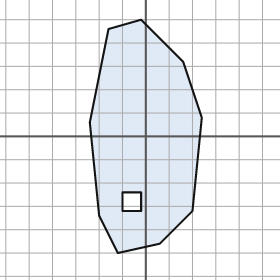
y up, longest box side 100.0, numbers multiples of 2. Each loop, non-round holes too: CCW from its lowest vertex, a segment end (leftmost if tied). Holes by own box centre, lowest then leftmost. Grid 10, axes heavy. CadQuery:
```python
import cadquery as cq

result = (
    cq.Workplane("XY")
    .moveTo(-12.0, -50.0)
    .lineTo(6.0, -46.0)
    .lineTo(20.0, -32.0)
    .lineTo(24.0, 8.0)
    .lineTo(16.0, 32.0)
    .lineTo(-2.0, 50.0)
    .lineTo(-16.0, 46.0)
    .lineTo(-24.0, 6.0)
    .lineTo(-20.0, -34.0)
    .close()
    .moveTo(-10.0, -32.0)
    .lineTo(-2.0, -32.0)
    .lineTo(-2.0, -24.0)
    .lineTo(-10.0, -24.0)
    .close()
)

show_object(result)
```